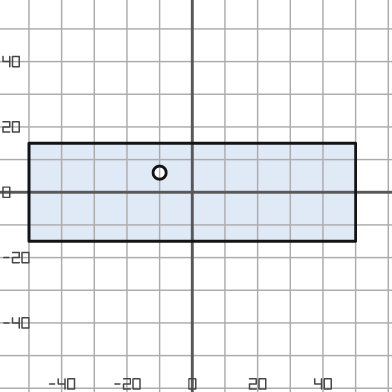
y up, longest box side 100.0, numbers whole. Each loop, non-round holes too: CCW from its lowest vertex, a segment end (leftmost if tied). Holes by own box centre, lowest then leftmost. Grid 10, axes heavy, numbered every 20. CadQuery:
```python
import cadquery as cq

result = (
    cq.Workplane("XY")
    .moveTo(-50.0, -15.0)
    .lineTo(50.0, -15.0)
    .lineTo(50.0, 15.0)
    .lineTo(-50.0, 15.0)
    .close()
    .moveTo(-10.0, 6.0)
    .circle(2.0)
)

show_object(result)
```